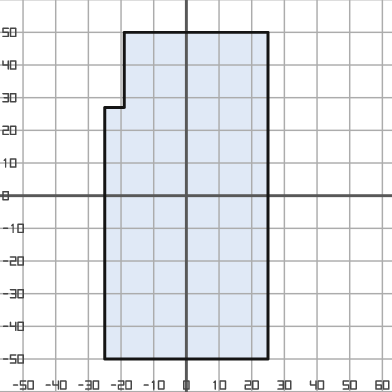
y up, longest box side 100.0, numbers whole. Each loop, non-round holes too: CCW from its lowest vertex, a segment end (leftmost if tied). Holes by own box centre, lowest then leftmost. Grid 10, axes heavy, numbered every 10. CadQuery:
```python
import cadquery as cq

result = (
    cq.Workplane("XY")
    .moveTo(-25.0, -50.0)
    .lineTo(25.0, -50.0)
    .lineTo(25.0, 50.0)
    .lineTo(-19.0, 50.0)
    .lineTo(-19.0, 27.0)
    .lineTo(-25.0, 27.0)
    .close()
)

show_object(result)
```